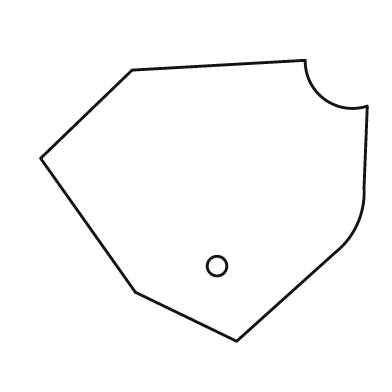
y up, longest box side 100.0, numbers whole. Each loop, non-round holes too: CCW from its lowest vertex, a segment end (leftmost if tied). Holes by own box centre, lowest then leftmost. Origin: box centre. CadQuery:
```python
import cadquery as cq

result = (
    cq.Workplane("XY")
    .moveTo(10.0, -43.0)
    .lineTo(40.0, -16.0)
    .threePointArc((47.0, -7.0), (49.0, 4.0))
    .lineTo(50.0, 29.0)
    .threePointArc((37.0, 31.0), (31.0, 43.0))
    .lineTo(-22.0, 40.0)
    .lineTo(-50.0, 13.0)
    .lineTo(-21.0, -28.0)
    .close()
    .moveTo(4.0, -20.0)
    .circle(3.0)
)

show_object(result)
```